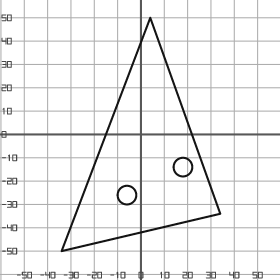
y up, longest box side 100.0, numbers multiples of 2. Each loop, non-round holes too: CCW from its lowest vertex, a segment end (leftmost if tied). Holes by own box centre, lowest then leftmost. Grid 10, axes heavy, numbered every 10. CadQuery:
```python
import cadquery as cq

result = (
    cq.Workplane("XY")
    .moveTo(-34.0, -50.0)
    .lineTo(34.0, -34.0)
    .lineTo(4.0, 50.0)
    .close()
    .moveTo(-6.0, -26.0)
    .circle(4.0)
    .moveTo(18.0, -14.0)
    .circle(4.0)
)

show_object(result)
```